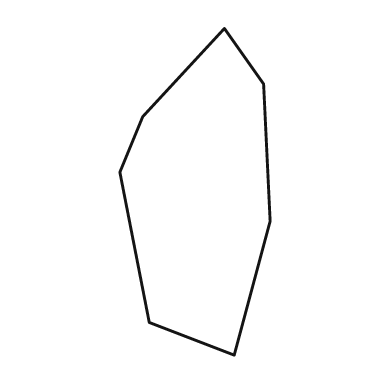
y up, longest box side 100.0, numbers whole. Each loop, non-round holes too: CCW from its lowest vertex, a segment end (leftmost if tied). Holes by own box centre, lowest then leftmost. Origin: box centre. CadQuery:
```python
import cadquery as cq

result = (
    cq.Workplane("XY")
    .moveTo(12.0, -50.0)
    .lineTo(23.0, -9.0)
    .lineTo(21.0, 33.0)
    .lineTo(9.0, 50.0)
    .lineTo(-16.0, 23.0)
    .lineTo(-23.0, 6.0)
    .lineTo(-14.0, -40.0)
    .close()
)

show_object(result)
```